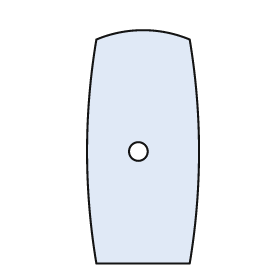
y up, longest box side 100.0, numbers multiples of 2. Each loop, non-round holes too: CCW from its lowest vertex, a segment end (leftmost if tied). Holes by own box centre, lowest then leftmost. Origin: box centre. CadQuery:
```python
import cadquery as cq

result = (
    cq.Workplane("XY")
    .moveTo(-20.0, -50.0)
    .lineTo(20.0, -50.0)
    .threePointArc((24.0, -2.0), (20.0, 46.0))
    .threePointArc((0.0, 50.0), (-20.0, 46.0))
    .threePointArc((-24.0, -2.0), (-20.0, -50.0))
    .close()
    .moveTo(-2.0, -2.0)
    .circle(4.0)
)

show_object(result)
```